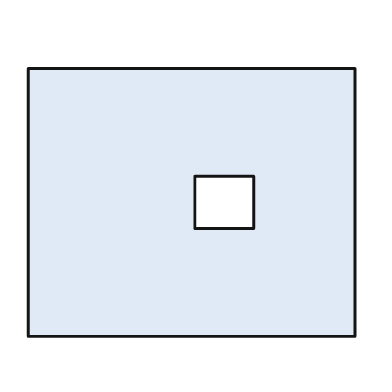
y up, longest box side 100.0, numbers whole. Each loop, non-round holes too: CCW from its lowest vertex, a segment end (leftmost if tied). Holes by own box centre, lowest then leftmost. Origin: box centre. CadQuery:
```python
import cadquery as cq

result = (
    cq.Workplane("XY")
    .moveTo(-50.0, -41.0)
    .lineTo(50.0, -41.0)
    .lineTo(50.0, 41.0)
    .lineTo(-50.0, 41.0)
    .close()
    .moveTo(1.0, -8.0)
    .lineTo(19.0, -8.0)
    .lineTo(19.0, 8.0)
    .lineTo(1.0, 8.0)
    .close()
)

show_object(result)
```